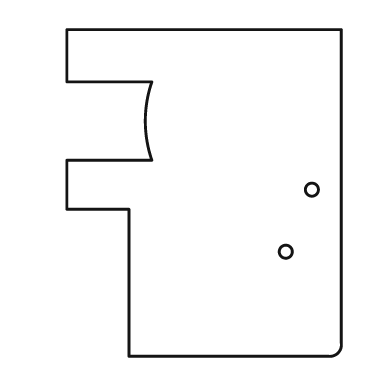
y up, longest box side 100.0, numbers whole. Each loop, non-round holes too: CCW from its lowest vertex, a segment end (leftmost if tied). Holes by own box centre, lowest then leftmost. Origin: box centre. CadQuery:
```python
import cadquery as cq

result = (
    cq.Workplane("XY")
    .moveTo(-23.0, -50.0)
    .lineTo(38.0, -50.0)
    .threePointArc((41.0, -49.0), (42.0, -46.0))
    .lineTo(42.0, 50.0)
    .lineTo(-42.0, 50.0)
    .lineTo(-42.0, 34.0)
    .lineTo(-16.0, 34.0)
    .threePointArc((-18.0, 22.0), (-16.0, 10.0))
    .lineTo(-42.0, 10.0)
    .lineTo(-42.0, -5.0)
    .lineTo(-23.0, -5.0)
    .close()
    .moveTo(25.0, -18.0)
    .circle(2.0)
    .moveTo(33.0, 1.0)
    .circle(2.0)
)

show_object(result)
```